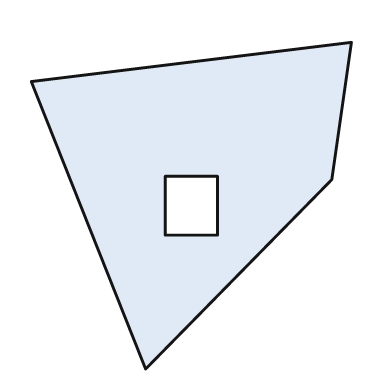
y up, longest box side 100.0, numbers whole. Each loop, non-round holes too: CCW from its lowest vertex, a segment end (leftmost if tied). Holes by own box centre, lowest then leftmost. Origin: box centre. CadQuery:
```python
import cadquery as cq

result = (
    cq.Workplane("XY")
    .moveTo(-14.0, -50.0)
    .lineTo(43.0, 8.0)
    .lineTo(49.0, 50.0)
    .lineTo(-49.0, 38.0)
    .close()
    .moveTo(-8.0, -9.0)
    .lineTo(8.0, -9.0)
    .lineTo(8.0, 9.0)
    .lineTo(-8.0, 9.0)
    .close()
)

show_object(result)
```